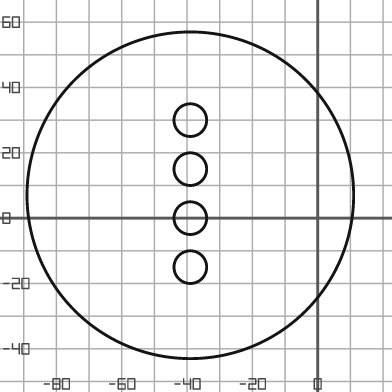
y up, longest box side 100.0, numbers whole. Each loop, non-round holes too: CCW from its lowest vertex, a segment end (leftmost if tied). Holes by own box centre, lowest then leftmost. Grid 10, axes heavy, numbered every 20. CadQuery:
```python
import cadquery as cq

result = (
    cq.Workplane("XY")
    .moveTo(-39.0, 7.0)
    .circle(50.0)
    .moveTo(-39.0, -15.0)
    .circle(5.0)
    .moveTo(-39.0, 0.0)
    .circle(5.0)
    .moveTo(-39.0, 15.0)
    .circle(5.0)
    .moveTo(-39.0, 30.0)
    .circle(5.0)
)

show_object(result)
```